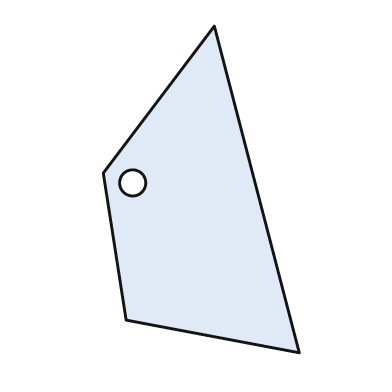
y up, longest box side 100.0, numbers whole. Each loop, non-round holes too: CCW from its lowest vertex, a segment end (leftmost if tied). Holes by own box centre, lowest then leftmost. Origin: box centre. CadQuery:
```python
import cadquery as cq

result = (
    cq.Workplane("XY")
    .moveTo(30.0, -50.0)
    .lineTo(4.0, 50.0)
    .lineTo(-30.0, 5.0)
    .lineTo(-23.0, -40.0)
    .close()
    .moveTo(-21.0, 2.0)
    .circle(4.0)
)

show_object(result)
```